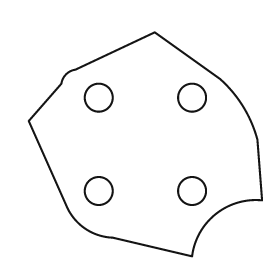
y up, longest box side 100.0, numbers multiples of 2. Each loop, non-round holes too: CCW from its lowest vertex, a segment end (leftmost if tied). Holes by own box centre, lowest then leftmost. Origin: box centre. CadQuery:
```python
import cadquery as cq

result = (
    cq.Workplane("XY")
    .moveTo(20.0, -48.0)
    .threePointArc((30.0, -30.0), (50.0, -24.0))
    .lineTo(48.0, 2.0)
    .threePointArc((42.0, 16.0), (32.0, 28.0))
    .lineTo(4.0, 48.0)
    .lineTo(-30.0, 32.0)
    .threePointArc((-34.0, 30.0), (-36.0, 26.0))
    .lineTo(-50.0, 10.0)
    .lineTo(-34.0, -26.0)
    .threePointArc((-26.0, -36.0), (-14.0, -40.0))
    .close()
    .moveTo(-20.0, -20.0)
    .circle(6.0)
    .moveTo(20.0, -20.0)
    .circle(6.0)
    .moveTo(-20.0, 20.0)
    .circle(6.0)
    .moveTo(20.0, 20.0)
    .circle(6.0)
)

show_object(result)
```